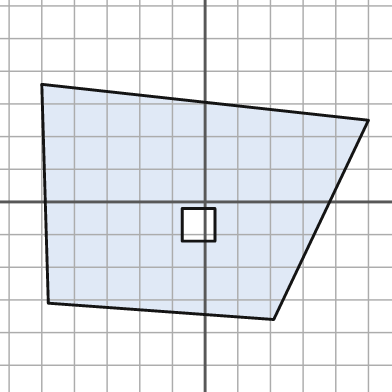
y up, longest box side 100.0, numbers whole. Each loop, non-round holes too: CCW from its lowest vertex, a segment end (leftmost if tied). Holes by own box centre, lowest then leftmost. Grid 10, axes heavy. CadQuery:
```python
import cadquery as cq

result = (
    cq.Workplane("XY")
    .moveTo(21.0, -36.0)
    .lineTo(50.0, 25.0)
    .lineTo(-50.0, 36.0)
    .lineTo(-48.0, -31.0)
    .close()
    .moveTo(-7.0, -12.0)
    .lineTo(3.0, -12.0)
    .lineTo(3.0, -2.0)
    .lineTo(-7.0, -2.0)
    .close()
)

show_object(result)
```